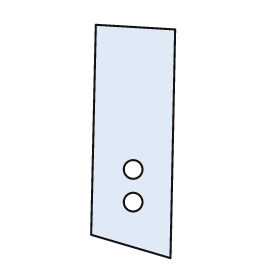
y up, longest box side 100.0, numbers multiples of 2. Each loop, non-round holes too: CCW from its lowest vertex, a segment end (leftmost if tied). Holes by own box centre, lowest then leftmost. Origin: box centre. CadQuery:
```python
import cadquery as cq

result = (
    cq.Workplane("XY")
    .moveTo(16.0, -50.0)
    .lineTo(18.0, 48.0)
    .lineTo(-16.0, 50.0)
    .lineTo(-18.0, -40.0)
    .close()
    .moveTo(0.0, -26.0)
    .circle(4.0)
    .moveTo(0.0, -12.0)
    .circle(4.0)
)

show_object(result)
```